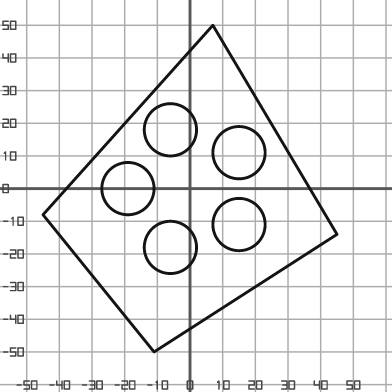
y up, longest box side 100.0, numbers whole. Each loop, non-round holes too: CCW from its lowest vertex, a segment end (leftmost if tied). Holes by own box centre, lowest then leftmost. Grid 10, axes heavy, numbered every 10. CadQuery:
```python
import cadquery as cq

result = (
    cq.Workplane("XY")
    .moveTo(-11.0, -50.0)
    .lineTo(45.0, -14.0)
    .lineTo(7.0, 50.0)
    .lineTo(-45.0, -8.0)
    .close()
    .moveTo(-6.0, -18.0)
    .circle(8.0)
    .moveTo(15.0, -11.0)
    .circle(8.0)
    .moveTo(-19.0, 0.0)
    .circle(8.0)
    .moveTo(15.0, 11.0)
    .circle(8.0)
    .moveTo(-6.0, 18.0)
    .circle(8.0)
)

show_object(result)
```